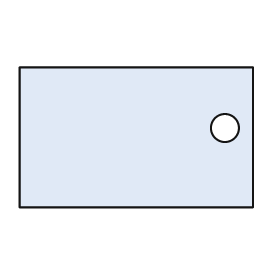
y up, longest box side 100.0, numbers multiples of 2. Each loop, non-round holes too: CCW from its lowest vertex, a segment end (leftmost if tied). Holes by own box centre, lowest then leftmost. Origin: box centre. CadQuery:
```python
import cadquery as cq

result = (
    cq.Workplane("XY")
    .moveTo(-50.0, -30.0)
    .lineTo(50.0, -30.0)
    .lineTo(50.0, 30.0)
    .lineTo(-50.0, 30.0)
    .close()
    .moveTo(38.0, 4.0)
    .circle(6.0)
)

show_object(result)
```